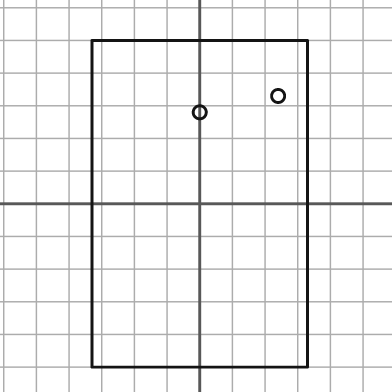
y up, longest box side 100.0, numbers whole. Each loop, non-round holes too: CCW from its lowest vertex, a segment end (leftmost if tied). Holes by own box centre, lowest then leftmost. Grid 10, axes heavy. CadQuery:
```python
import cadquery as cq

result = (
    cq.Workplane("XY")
    .moveTo(-33.0, -50.0)
    .lineTo(33.0, -50.0)
    .lineTo(33.0, 50.0)
    .lineTo(-33.0, 50.0)
    .close()
    .moveTo(0.0, 28.0)
    .circle(2.0)
    .moveTo(24.0, 33.0)
    .circle(2.0)
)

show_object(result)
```